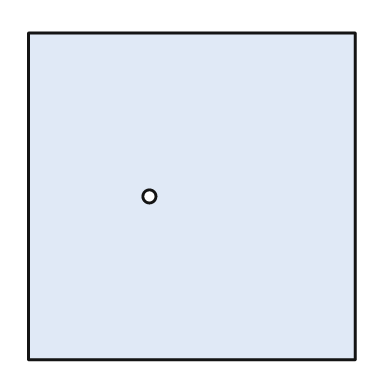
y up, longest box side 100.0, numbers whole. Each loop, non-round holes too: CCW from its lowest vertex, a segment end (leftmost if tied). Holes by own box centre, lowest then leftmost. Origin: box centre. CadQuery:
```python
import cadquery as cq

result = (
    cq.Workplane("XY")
    .moveTo(-50.0, -50.0)
    .lineTo(50.0, -50.0)
    .lineTo(50.0, 50.0)
    .lineTo(-50.0, 50.0)
    .close()
    .moveTo(-13.0, 0.0)
    .circle(2.0)
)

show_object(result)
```